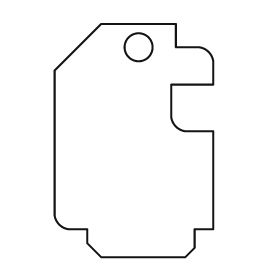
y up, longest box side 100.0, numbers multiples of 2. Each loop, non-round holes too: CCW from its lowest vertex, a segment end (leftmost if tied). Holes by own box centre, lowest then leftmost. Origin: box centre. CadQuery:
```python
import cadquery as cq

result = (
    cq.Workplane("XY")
    .moveTo(-14.0, -50.0)
    .lineTo(22.0, -50.0)
    .lineTo(26.0, -46.0)
    .lineTo(26.0, -38.0)
    .lineTo(34.0, -38.0)
    .lineTo(34.0, 4.0)
    .lineTo(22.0, 4.0)
    .threePointArc((18.0, 6.0), (16.0, 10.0))
    .lineTo(16.0, 24.0)
    .lineTo(34.0, 24.0)
    .lineTo(34.0, 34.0)
    .threePointArc((32.0, 38.0), (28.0, 40.0))
    .lineTo(18.0, 40.0)
    .lineTo(18.0, 50.0)
    .lineTo(-14.0, 50.0)
    .lineTo(-34.0, 30.0)
    .lineTo(-34.0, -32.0)
    .threePointArc((-32.0, -36.0), (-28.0, -38.0))
    .lineTo(-20.0, -38.0)
    .lineTo(-20.0, -44.0)
    .close()
    .moveTo(2.0, 40.0)
    .circle(6.0)
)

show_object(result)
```